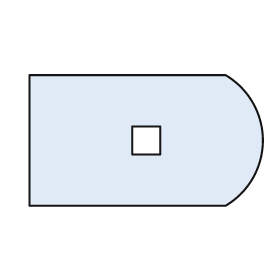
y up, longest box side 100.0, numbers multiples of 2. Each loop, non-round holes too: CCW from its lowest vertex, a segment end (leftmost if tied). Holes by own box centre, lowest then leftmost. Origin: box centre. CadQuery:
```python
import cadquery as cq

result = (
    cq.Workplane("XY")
    .moveTo(-50.0, -28.0)
    .lineTo(34.0, -28.0)
    .threePointArc((50.0, 0.0), (34.0, 28.0))
    .lineTo(-50.0, 28.0)
    .close()
    .moveTo(-6.0, -6.0)
    .lineTo(6.0, -6.0)
    .lineTo(6.0, 6.0)
    .lineTo(-6.0, 6.0)
    .close()
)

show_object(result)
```